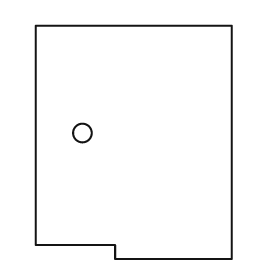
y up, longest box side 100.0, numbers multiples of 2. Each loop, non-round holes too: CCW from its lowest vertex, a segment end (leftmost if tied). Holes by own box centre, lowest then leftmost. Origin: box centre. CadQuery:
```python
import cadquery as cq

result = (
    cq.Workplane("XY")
    .moveTo(-8.0, -50.0)
    .lineTo(42.0, -50.0)
    .lineTo(42.0, 50.0)
    .lineTo(-42.0, 50.0)
    .lineTo(-42.0, -44.0)
    .lineTo(-8.0, -44.0)
    .close()
    .moveTo(-22.0, 4.0)
    .circle(4.0)
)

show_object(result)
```